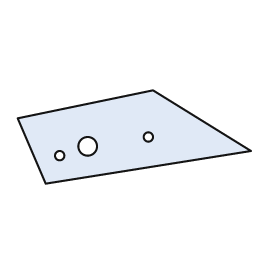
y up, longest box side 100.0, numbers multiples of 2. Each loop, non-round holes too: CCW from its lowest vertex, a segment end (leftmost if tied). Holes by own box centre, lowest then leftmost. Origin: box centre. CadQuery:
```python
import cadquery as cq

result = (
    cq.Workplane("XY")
    .moveTo(-38.0, -20.0)
    .lineTo(50.0, -6.0)
    .lineTo(8.0, 20.0)
    .lineTo(-50.0, 8.0)
    .close()
    .moveTo(-32.0, -8.0)
    .circle(2.0)
    .moveTo(-20.0, -4.0)
    .circle(4.0)
    .moveTo(6.0, 0.0)
    .circle(2.0)
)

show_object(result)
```